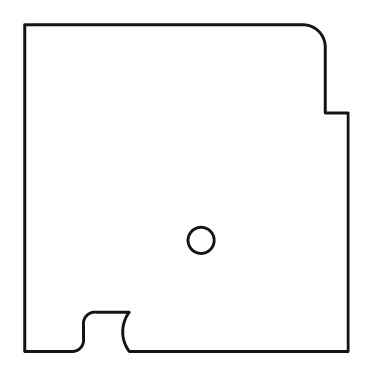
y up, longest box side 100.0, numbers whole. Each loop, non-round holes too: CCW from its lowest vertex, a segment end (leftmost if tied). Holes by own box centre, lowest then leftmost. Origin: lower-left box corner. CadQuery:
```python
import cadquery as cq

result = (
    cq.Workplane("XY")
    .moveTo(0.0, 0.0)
    .lineTo(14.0, 0.0)
    .threePointArc((17.0, 1.0), (18.0, 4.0))
    .lineTo(18.0, 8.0)
    .threePointArc((19.0, 11.0), (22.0, 12.0))
    .lineTo(32.0, 12.0)
    .threePointArc((30.0, 6.0), (32.0, 0.0))
    .lineTo(99.0, 0.0)
    .lineTo(99.0, 73.0)
    .lineTo(92.0, 73.0)
    .lineTo(92.0, 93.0)
    .threePointArc((90.0, 98.0), (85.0, 100.0))
    .lineTo(0.0, 100.0)
    .close()
    .moveTo(54.0, 34.0)
    .circle(4.0)
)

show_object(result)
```